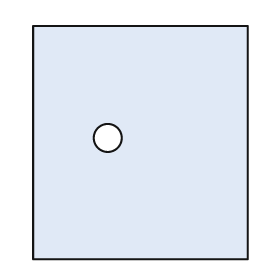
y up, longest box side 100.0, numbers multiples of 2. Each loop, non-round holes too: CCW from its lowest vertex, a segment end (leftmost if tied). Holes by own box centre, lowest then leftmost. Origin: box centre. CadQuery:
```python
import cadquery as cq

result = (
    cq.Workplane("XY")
    .moveTo(-46.0, -50.0)
    .lineTo(46.0, -50.0)
    .lineTo(46.0, 50.0)
    .lineTo(-46.0, 50.0)
    .close()
    .moveTo(-14.0, 2.0)
    .circle(6.0)
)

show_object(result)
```